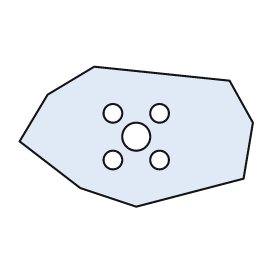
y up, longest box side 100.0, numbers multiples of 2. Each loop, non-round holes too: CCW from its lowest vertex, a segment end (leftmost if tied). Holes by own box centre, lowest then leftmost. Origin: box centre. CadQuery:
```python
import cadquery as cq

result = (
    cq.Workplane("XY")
    .moveTo(0.0, -30.0)
    .lineTo(46.0, -18.0)
    .lineTo(50.0, 6.0)
    .lineTo(40.0, 24.0)
    .lineTo(-18.0, 30.0)
    .lineTo(-38.0, 18.0)
    .lineTo(-50.0, -2.0)
    .lineTo(-24.0, -22.0)
    .close()
    .moveTo(-10.0, -10.0)
    .circle(4.0)
    .moveTo(10.0, -10.0)
    .circle(4.0)
    .moveTo(0.0, 0.0)
    .circle(6.0)
    .moveTo(-10.0, 10.0)
    .circle(4.0)
    .moveTo(10.0, 10.0)
    .circle(4.0)
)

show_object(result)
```